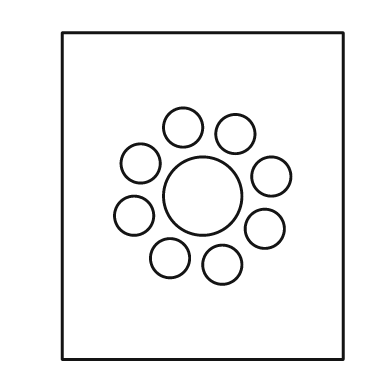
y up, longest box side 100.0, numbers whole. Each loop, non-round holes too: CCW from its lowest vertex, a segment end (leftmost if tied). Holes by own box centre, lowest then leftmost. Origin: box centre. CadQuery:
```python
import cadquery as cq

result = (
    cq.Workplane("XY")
    .moveTo(-43.0, -50.0)
    .lineTo(43.0, -50.0)
    .lineTo(43.0, 50.0)
    .lineTo(-43.0, 50.0)
    .close()
    .moveTo(6.0, -21.0)
    .circle(6.0)
    .moveTo(-10.0, -19.0)
    .circle(6.0)
    .moveTo(19.0, -10.0)
    .circle(6.0)
    .moveTo(-21.0, -6.0)
    .circle(6.0)
    .moveTo(0.0, 0.0)
    .circle(12.0)
    .moveTo(21.0, 6.0)
    .circle(6.0)
    .moveTo(-19.0, 10.0)
    .circle(6.0)
    .moveTo(10.0, 19.0)
    .circle(6.0)
    .moveTo(-6.0, 21.0)
    .circle(6.0)
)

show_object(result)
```